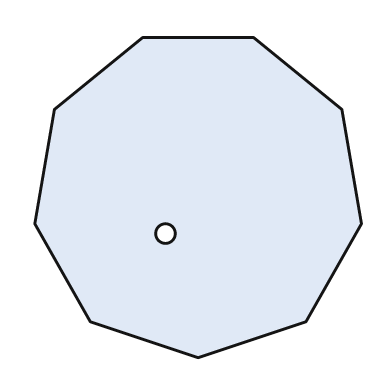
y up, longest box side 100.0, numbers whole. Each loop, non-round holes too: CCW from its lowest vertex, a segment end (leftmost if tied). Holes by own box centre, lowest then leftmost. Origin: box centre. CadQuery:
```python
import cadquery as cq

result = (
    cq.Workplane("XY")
    .moveTo(0.0, -49.0)
    .lineTo(33.0, -38.0)
    .lineTo(50.0, -8.0)
    .lineTo(44.0, 27.0)
    .lineTo(17.0, 49.0)
    .lineTo(-17.0, 49.0)
    .lineTo(-44.0, 27.0)
    .lineTo(-50.0, -8.0)
    .lineTo(-33.0, -38.0)
    .close()
    .moveTo(-10.0, -11.0)
    .circle(3.0)
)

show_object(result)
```